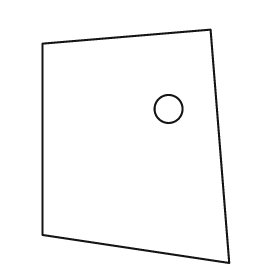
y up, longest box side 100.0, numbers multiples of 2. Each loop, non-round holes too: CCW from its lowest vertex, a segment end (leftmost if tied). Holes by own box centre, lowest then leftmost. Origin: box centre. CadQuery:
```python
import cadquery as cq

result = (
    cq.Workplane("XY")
    .moveTo(40.0, -50.0)
    .lineTo(32.0, 50.0)
    .lineTo(-40.0, 44.0)
    .lineTo(-40.0, -38.0)
    .close()
    .moveTo(14.0, 16.0)
    .circle(6.0)
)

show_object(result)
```